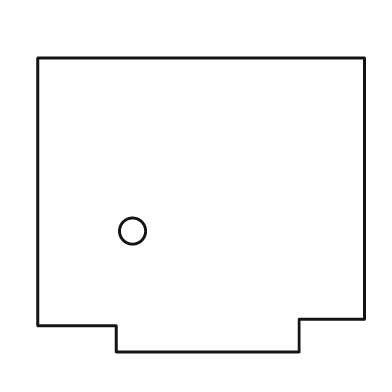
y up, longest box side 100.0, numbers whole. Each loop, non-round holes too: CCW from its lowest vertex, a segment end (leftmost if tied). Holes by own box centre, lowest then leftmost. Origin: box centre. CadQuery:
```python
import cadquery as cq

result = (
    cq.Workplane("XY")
    .moveTo(-26.0, -45.0)
    .lineTo(30.0, -45.0)
    .lineTo(30.0, -35.0)
    .lineTo(50.0, -35.0)
    .lineTo(50.0, 45.0)
    .lineTo(-50.0, 45.0)
    .lineTo(-50.0, -37.0)
    .lineTo(-26.0, -37.0)
    .close()
    .moveTo(-21.0, -8.0)
    .circle(4.0)
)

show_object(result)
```